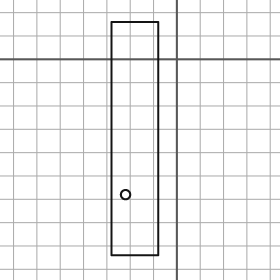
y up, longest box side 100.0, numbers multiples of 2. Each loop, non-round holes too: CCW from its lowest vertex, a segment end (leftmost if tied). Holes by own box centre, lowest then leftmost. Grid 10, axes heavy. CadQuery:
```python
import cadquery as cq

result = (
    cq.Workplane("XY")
    .moveTo(-28.0, -84.0)
    .lineTo(-8.0, -84.0)
    .lineTo(-8.0, 16.0)
    .lineTo(-28.0, 16.0)
    .close()
    .moveTo(-22.0, -58.0)
    .circle(2.0)
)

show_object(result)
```